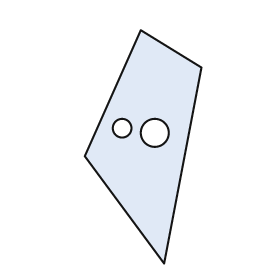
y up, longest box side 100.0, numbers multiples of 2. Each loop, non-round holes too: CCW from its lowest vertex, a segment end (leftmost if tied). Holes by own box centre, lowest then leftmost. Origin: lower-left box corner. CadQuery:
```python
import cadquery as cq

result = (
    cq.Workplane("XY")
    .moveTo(34.0, 0.0)
    .lineTo(50.0, 84.0)
    .lineTo(24.0, 100.0)
    .lineTo(0.0, 46.0)
    .close()
    .moveTo(30.0, 56.0)
    .circle(6.0)
    .moveTo(16.0, 58.0)
    .circle(4.0)
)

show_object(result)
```